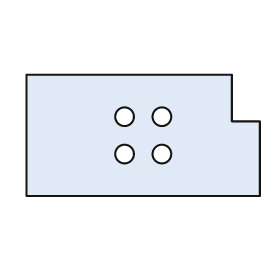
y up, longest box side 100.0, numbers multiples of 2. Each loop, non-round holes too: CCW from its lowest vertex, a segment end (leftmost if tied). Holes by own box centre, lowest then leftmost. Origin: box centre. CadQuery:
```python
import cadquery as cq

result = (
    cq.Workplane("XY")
    .moveTo(-50.0, -26.0)
    .lineTo(50.0, -26.0)
    .lineTo(50.0, 6.0)
    .lineTo(38.0, 6.0)
    .lineTo(38.0, 26.0)
    .lineTo(-50.0, 26.0)
    .close()
    .moveTo(-8.0, -8.0)
    .circle(4.0)
    .moveTo(8.0, -8.0)
    .circle(4.0)
    .moveTo(-8.0, 8.0)
    .circle(4.0)
    .moveTo(8.0, 8.0)
    .circle(4.0)
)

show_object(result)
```